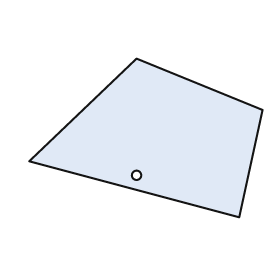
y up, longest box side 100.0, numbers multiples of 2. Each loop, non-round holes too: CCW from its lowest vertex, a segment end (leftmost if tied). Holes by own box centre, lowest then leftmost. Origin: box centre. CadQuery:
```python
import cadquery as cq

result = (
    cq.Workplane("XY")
    .moveTo(40.0, -34.0)
    .lineTo(50.0, 12.0)
    .lineTo(-4.0, 34.0)
    .lineTo(-50.0, -10.0)
    .close()
    .moveTo(-4.0, -16.0)
    .circle(2.0)
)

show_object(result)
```